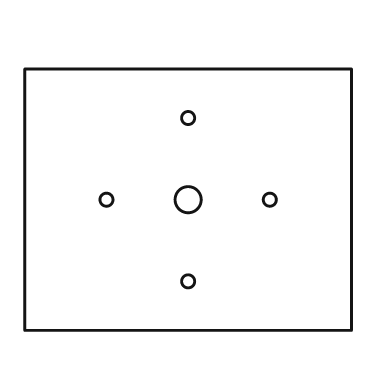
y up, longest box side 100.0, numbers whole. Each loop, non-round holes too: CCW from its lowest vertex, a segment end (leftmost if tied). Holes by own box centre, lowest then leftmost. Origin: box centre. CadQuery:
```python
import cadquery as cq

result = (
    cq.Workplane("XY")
    .moveTo(-50.0, -40.0)
    .lineTo(50.0, -40.0)
    .lineTo(50.0, 40.0)
    .lineTo(-50.0, 40.0)
    .close()
    .moveTo(0.0, -25.0)
    .circle(2.0)
    .moveTo(-25.0, 0.0)
    .circle(2.0)
    .moveTo(0.0, 0.0)
    .circle(4.0)
    .moveTo(25.0, 0.0)
    .circle(2.0)
    .moveTo(0.0, 25.0)
    .circle(2.0)
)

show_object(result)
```